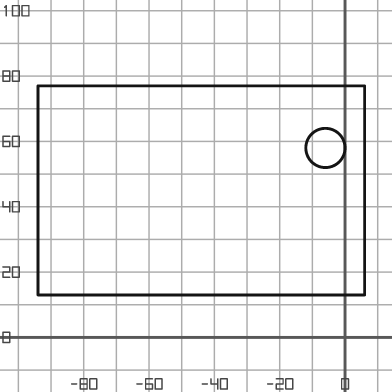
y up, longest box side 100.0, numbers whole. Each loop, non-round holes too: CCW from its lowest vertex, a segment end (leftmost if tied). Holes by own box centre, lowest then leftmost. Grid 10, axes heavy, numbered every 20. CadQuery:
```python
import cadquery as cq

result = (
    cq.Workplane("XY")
    .moveTo(-94.0, 13.0)
    .lineTo(6.0, 13.0)
    .lineTo(6.0, 77.0)
    .lineTo(-94.0, 77.0)
    .close()
    .moveTo(-6.0, 58.0)
    .circle(6.0)
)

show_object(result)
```